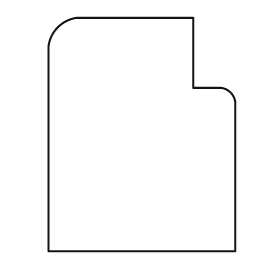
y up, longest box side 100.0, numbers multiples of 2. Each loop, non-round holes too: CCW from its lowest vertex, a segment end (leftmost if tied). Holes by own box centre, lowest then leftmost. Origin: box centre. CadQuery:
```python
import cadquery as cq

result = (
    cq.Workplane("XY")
    .moveTo(-40.0, -50.0)
    .lineTo(40.0, -50.0)
    .lineTo(40.0, 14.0)
    .threePointArc((38.0, 18.0), (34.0, 20.0))
    .lineTo(22.0, 20.0)
    .lineTo(22.0, 50.0)
    .lineTo(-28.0, 50.0)
    .threePointArc((-36.0, 46.0), (-40.0, 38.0))
    .close()
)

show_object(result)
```